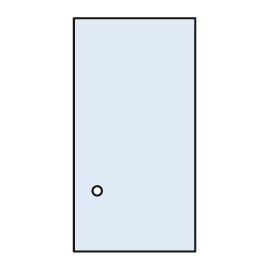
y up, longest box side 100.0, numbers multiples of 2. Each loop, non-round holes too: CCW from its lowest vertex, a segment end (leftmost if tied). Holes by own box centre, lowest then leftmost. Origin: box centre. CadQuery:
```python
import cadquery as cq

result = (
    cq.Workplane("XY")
    .moveTo(-26.0, -50.0)
    .lineTo(26.0, -50.0)
    .lineTo(26.0, 50.0)
    .lineTo(-26.0, 50.0)
    .close()
    .moveTo(-16.0, -24.0)
    .circle(2.0)
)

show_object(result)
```